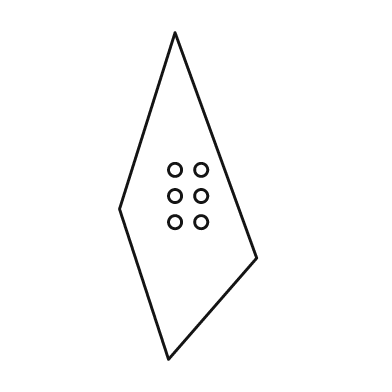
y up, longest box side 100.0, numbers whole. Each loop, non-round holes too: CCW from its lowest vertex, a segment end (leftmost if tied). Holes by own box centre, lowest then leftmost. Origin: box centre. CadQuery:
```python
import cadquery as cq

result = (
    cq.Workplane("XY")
    .moveTo(-6.0, -50.0)
    .lineTo(21.0, -19.0)
    .lineTo(-4.0, 50.0)
    .lineTo(-21.0, -4.0)
    .close()
    .moveTo(-4.0, -8.0)
    .circle(2.0)
    .moveTo(4.0, -8.0)
    .circle(2.0)
    .moveTo(-4.0, 0.0)
    .circle(2.0)
    .moveTo(4.0, 0.0)
    .circle(2.0)
    .moveTo(-4.0, 8.0)
    .circle(2.0)
    .moveTo(4.0, 8.0)
    .circle(2.0)
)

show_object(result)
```